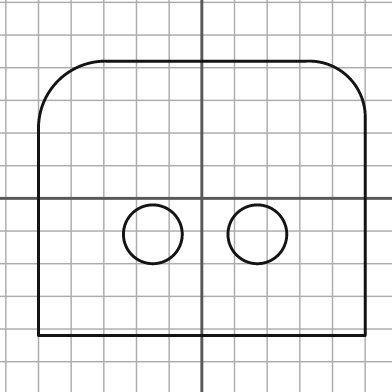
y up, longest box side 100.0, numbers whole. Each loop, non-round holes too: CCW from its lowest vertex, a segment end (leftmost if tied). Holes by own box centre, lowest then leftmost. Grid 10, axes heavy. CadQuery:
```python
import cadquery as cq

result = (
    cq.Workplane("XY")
    .moveTo(-50.0, -42.0)
    .lineTo(50.0, -42.0)
    .lineTo(50.0, 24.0)
    .threePointArc((45.0, 37.0), (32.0, 42.0))
    .lineTo(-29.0, 42.0)
    .threePointArc((-44.0, 36.0), (-50.0, 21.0))
    .close()
    .moveTo(-15.0, -11.0)
    .circle(9.0)
    .moveTo(17.0, -11.0)
    .circle(9.0)
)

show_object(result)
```